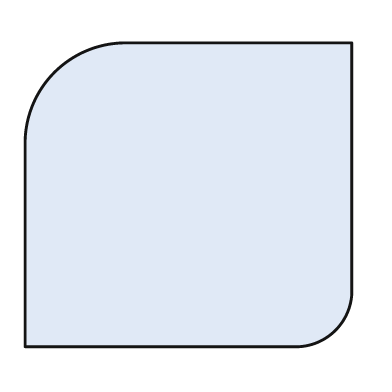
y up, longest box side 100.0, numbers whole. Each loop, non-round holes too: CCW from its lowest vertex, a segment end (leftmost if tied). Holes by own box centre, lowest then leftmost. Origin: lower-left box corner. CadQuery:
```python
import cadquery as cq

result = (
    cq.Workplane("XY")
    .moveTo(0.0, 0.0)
    .lineTo(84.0, 0.0)
    .threePointArc((95.0, 5.0), (100.0, 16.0))
    .lineTo(100.0, 93.0)
    .lineTo(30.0, 93.0)
    .threePointArc((9.0, 84.0), (0.0, 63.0))
    .close()
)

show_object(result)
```